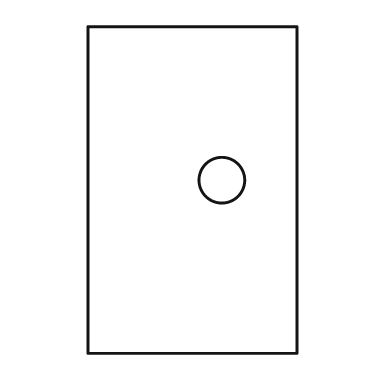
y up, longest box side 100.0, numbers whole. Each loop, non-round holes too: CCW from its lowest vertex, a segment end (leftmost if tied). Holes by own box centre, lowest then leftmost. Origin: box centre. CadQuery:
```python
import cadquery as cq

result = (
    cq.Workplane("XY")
    .moveTo(-32.0, -50.0)
    .lineTo(32.0, -50.0)
    .lineTo(32.0, 50.0)
    .lineTo(-32.0, 50.0)
    .close()
    .moveTo(9.0, 3.0)
    .circle(7.0)
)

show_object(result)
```